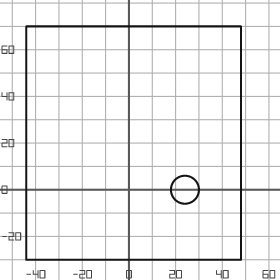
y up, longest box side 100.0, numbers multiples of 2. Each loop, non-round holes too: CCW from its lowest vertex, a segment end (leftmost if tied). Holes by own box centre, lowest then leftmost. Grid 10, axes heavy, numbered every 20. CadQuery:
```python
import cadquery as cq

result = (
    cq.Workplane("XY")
    .moveTo(-44.0, -30.0)
    .lineTo(48.0, -30.0)
    .lineTo(48.0, 70.0)
    .lineTo(-44.0, 70.0)
    .close()
    .moveTo(24.0, 0.0)
    .circle(6.0)
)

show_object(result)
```